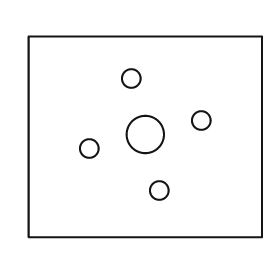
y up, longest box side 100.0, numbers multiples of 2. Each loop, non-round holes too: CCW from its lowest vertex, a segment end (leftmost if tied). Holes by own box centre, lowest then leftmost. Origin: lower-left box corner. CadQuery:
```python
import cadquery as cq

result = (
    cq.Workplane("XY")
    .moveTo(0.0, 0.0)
    .lineTo(100.0, 0.0)
    .lineTo(100.0, 86.0)
    .lineTo(0.0, 86.0)
    .close()
    .moveTo(56.0, 20.0)
    .circle(4.0)
    .moveTo(26.0, 38.0)
    .circle(4.0)
    .moveTo(50.0, 44.0)
    .circle(8.0)
    .moveTo(74.0, 50.0)
    .circle(4.0)
    .moveTo(44.0, 68.0)
    .circle(4.0)
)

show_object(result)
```